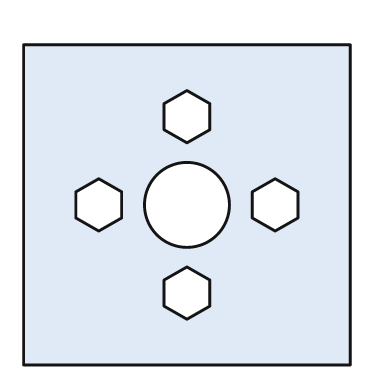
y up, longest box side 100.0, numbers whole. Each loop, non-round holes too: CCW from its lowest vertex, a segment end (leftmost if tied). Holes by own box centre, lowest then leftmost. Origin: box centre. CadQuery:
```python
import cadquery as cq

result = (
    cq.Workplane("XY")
    .moveTo(-50.0, -49.0)
    .lineTo(50.0, -49.0)
    .lineTo(50.0, 49.0)
    .lineTo(-50.0, 49.0)
    .close()
    .moveTo(0.0, -35.0)
    .lineTo(7.0, -31.0)
    .lineTo(7.0, -23.0)
    .lineTo(0.0, -19.0)
    .lineTo(-7.0, -23.0)
    .lineTo(-7.0, -31.0)
    .close()
    .moveTo(-27.0, -8.0)
    .lineTo(-20.0, -4.0)
    .lineTo(-20.0, 4.0)
    .lineTo(-27.0, 8.0)
    .lineTo(-34.0, 4.0)
    .lineTo(-34.0, -4.0)
    .close()
    .moveTo(0.0, 0.0)
    .circle(13.0)
    .moveTo(27.0, -8.0)
    .lineTo(34.0, -4.0)
    .lineTo(34.0, 4.0)
    .lineTo(27.0, 8.0)
    .lineTo(20.0, 4.0)
    .lineTo(20.0, -4.0)
    .close()
    .moveTo(0.0, 19.0)
    .lineTo(7.0, 23.0)
    .lineTo(7.0, 31.0)
    .lineTo(0.0, 35.0)
    .lineTo(-7.0, 31.0)
    .lineTo(-7.0, 23.0)
    .close()
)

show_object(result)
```